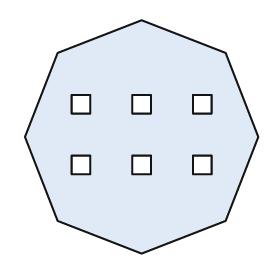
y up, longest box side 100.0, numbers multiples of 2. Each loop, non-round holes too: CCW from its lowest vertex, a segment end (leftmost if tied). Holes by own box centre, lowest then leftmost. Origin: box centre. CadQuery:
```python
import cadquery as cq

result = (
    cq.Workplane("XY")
    .moveTo(0.0, -50.0)
    .lineTo(36.0, -36.0)
    .lineTo(50.0, 0.0)
    .lineTo(36.0, 36.0)
    .lineTo(0.0, 50.0)
    .lineTo(-36.0, 36.0)
    .lineTo(-50.0, 0.0)
    .lineTo(-36.0, -36.0)
    .close()
    .moveTo(-30.0, -16.0)
    .lineTo(-22.0, -16.0)
    .lineTo(-22.0, -8.0)
    .lineTo(-30.0, -8.0)
    .close()
    .moveTo(-4.0, -16.0)
    .lineTo(4.0, -16.0)
    .lineTo(4.0, -8.0)
    .lineTo(-4.0, -8.0)
    .close()
    .moveTo(22.0, -16.0)
    .lineTo(30.0, -16.0)
    .lineTo(30.0, -8.0)
    .lineTo(22.0, -8.0)
    .close()
    .moveTo(-30.0, 10.0)
    .lineTo(-22.0, 10.0)
    .lineTo(-22.0, 18.0)
    .lineTo(-30.0, 18.0)
    .close()
    .moveTo(-4.0, 10.0)
    .lineTo(4.0, 10.0)
    .lineTo(4.0, 18.0)
    .lineTo(-4.0, 18.0)
    .close()
    .moveTo(22.0, 10.0)
    .lineTo(30.0, 10.0)
    .lineTo(30.0, 18.0)
    .lineTo(22.0, 18.0)
    .close()
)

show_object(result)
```